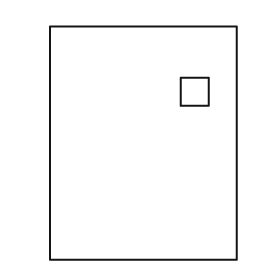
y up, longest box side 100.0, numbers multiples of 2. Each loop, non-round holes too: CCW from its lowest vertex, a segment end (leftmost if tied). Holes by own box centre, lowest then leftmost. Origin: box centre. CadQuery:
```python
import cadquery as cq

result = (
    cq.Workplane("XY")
    .moveTo(-40.0, -50.0)
    .lineTo(40.0, -50.0)
    .lineTo(40.0, 50.0)
    .lineTo(-40.0, 50.0)
    .close()
    .moveTo(16.0, 16.0)
    .lineTo(28.0, 16.0)
    .lineTo(28.0, 28.0)
    .lineTo(16.0, 28.0)
    .close()
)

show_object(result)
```